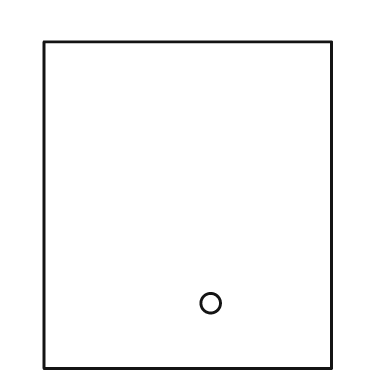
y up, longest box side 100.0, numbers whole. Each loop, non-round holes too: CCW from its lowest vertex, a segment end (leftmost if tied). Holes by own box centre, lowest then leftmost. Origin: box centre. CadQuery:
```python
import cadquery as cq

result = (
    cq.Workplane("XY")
    .moveTo(-44.0, -50.0)
    .lineTo(44.0, -50.0)
    .lineTo(44.0, 50.0)
    .lineTo(-44.0, 50.0)
    .close()
    .moveTo(7.0, -30.0)
    .circle(3.0)
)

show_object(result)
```